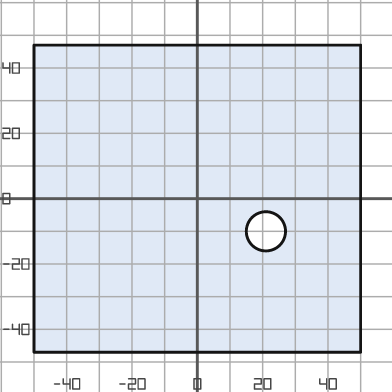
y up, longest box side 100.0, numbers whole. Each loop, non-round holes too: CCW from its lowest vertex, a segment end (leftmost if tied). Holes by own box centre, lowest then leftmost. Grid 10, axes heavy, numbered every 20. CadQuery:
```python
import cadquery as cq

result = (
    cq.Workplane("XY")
    .moveTo(-50.0, -47.0)
    .lineTo(50.0, -47.0)
    .lineTo(50.0, 47.0)
    .lineTo(-50.0, 47.0)
    .close()
    .moveTo(21.0, -10.0)
    .circle(6.0)
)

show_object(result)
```